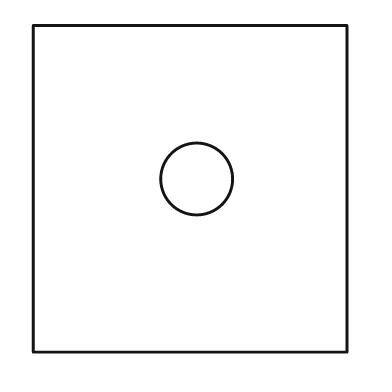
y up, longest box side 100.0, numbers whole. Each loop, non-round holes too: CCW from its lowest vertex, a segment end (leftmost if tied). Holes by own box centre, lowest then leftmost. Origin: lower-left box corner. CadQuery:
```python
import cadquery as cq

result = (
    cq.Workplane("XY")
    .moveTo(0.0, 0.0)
    .lineTo(96.0, 0.0)
    .lineTo(96.0, 100.0)
    .lineTo(0.0, 100.0)
    .close()
    .moveTo(50.0, 53.0)
    .circle(11.0)
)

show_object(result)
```